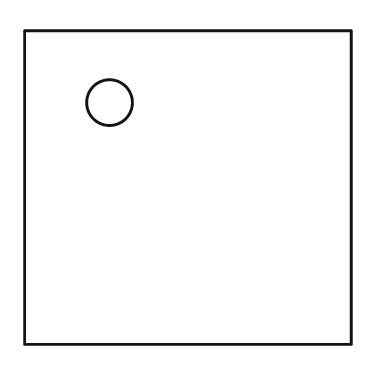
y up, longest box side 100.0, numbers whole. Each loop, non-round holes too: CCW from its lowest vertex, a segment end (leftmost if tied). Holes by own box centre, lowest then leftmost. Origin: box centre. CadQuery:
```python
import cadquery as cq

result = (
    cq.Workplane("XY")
    .moveTo(-50.0, -48.0)
    .lineTo(50.0, -48.0)
    .lineTo(50.0, 48.0)
    .lineTo(-50.0, 48.0)
    .close()
    .moveTo(-24.0, 26.0)
    .circle(7.0)
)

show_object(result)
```